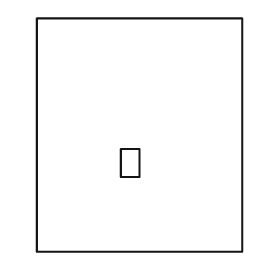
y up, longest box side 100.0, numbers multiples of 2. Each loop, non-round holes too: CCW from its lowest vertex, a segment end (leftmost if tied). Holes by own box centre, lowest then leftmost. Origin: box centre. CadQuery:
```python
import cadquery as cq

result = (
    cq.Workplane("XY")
    .moveTo(-44.0, -50.0)
    .lineTo(44.0, -50.0)
    .lineTo(44.0, 50.0)
    .lineTo(-44.0, 50.0)
    .close()
    .moveTo(-8.0, -18.0)
    .lineTo(0.0, -18.0)
    .lineTo(0.0, -6.0)
    .lineTo(-8.0, -6.0)
    .close()
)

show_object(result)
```